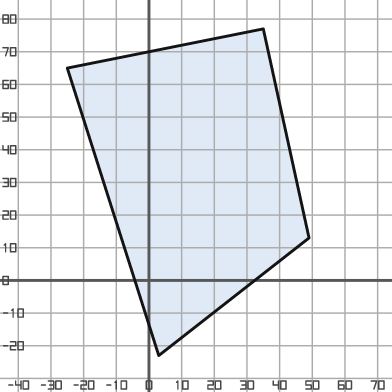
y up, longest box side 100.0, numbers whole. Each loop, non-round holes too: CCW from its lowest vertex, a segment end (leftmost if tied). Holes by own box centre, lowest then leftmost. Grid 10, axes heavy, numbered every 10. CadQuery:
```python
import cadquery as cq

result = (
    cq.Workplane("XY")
    .moveTo(3.0, -23.0)
    .lineTo(49.0, 13.0)
    .lineTo(35.0, 77.0)
    .lineTo(-25.0, 65.0)
    .close()
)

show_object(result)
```